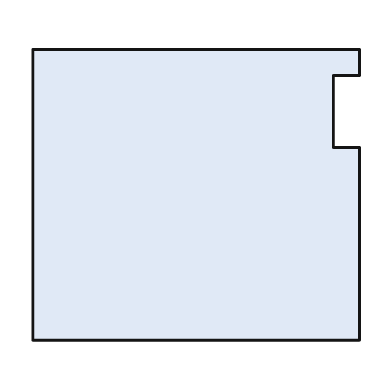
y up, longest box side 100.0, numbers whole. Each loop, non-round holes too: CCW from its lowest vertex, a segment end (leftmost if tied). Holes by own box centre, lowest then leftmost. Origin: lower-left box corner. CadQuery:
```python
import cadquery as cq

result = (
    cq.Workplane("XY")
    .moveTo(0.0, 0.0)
    .lineTo(100.0, 0.0)
    .lineTo(100.0, 59.0)
    .lineTo(92.0, 59.0)
    .lineTo(92.0, 81.0)
    .lineTo(100.0, 81.0)
    .lineTo(100.0, 89.0)
    .lineTo(0.0, 89.0)
    .close()
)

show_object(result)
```